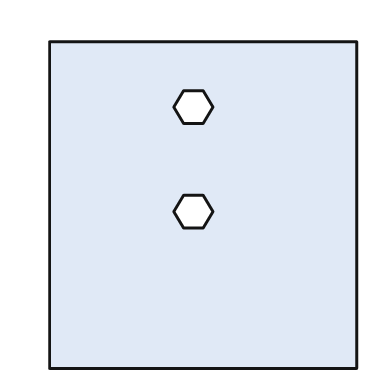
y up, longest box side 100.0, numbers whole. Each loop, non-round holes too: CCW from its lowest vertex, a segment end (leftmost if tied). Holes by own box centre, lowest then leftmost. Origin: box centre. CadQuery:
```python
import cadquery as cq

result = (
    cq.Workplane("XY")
    .moveTo(-47.0, -50.0)
    .lineTo(47.0, -50.0)
    .lineTo(47.0, 50.0)
    .lineTo(-47.0, 50.0)
    .close()
    .moveTo(-6.0, -7.0)
    .lineTo(0.0, -7.0)
    .lineTo(3.0, -2.0)
    .lineTo(0.0, 3.0)
    .lineTo(-6.0, 3.0)
    .lineTo(-9.0, -2.0)
    .close()
    .moveTo(-6.0, 25.0)
    .lineTo(0.0, 25.0)
    .lineTo(3.0, 30.0)
    .lineTo(0.0, 35.0)
    .lineTo(-6.0, 35.0)
    .lineTo(-9.0, 30.0)
    .close()
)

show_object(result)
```